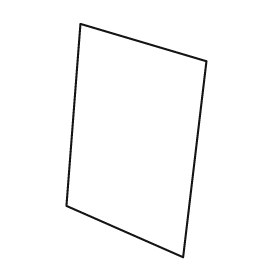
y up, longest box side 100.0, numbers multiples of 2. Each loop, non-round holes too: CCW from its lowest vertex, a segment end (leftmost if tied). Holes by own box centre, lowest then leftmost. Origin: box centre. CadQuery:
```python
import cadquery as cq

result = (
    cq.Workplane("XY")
    .moveTo(20.0, -50.0)
    .lineTo(30.0, 34.0)
    .lineTo(-24.0, 50.0)
    .lineTo(-30.0, -28.0)
    .close()
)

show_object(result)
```